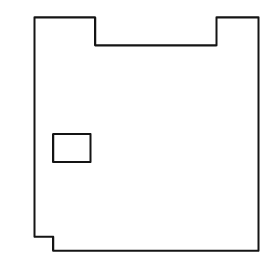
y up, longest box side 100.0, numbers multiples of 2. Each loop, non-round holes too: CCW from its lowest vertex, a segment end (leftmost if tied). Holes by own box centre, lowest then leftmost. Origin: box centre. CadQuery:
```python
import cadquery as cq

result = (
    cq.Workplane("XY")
    .moveTo(-40.0, -50.0)
    .lineTo(48.0, -50.0)
    .lineTo(48.0, 50.0)
    .lineTo(30.0, 50.0)
    .lineTo(30.0, 38.0)
    .lineTo(-22.0, 38.0)
    .lineTo(-22.0, 50.0)
    .lineTo(-48.0, 50.0)
    .lineTo(-48.0, -44.0)
    .lineTo(-40.0, -44.0)
    .close()
    .moveTo(-40.0, -12.0)
    .lineTo(-24.0, -12.0)
    .lineTo(-24.0, 0.0)
    .lineTo(-40.0, 0.0)
    .close()
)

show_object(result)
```